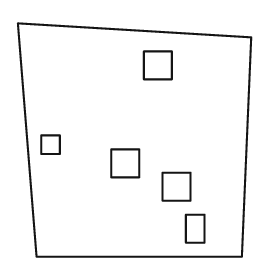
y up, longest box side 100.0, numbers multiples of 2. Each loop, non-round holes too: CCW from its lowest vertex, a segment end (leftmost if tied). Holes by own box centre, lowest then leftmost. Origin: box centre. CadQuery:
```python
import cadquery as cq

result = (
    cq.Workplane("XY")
    .moveTo(-42.0, -50.0)
    .lineTo(46.0, -50.0)
    .lineTo(50.0, 44.0)
    .lineTo(-50.0, 50.0)
    .close()
    .moveTo(22.0, -44.0)
    .lineTo(30.0, -44.0)
    .lineTo(30.0, -32.0)
    .lineTo(22.0, -32.0)
    .close()
    .moveTo(12.0, -26.0)
    .lineTo(24.0, -26.0)
    .lineTo(24.0, -14.0)
    .lineTo(12.0, -14.0)
    .close()
    .moveTo(-10.0, -16.0)
    .lineTo(2.0, -16.0)
    .lineTo(2.0, -4.0)
    .lineTo(-10.0, -4.0)
    .close()
    .moveTo(-40.0, -6.0)
    .lineTo(-32.0, -6.0)
    .lineTo(-32.0, 2.0)
    .lineTo(-40.0, 2.0)
    .close()
    .moveTo(4.0, 26.0)
    .lineTo(16.0, 26.0)
    .lineTo(16.0, 38.0)
    .lineTo(4.0, 38.0)
    .close()
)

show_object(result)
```